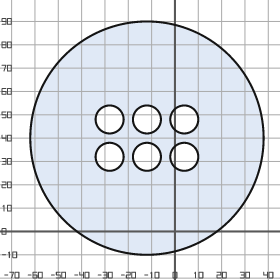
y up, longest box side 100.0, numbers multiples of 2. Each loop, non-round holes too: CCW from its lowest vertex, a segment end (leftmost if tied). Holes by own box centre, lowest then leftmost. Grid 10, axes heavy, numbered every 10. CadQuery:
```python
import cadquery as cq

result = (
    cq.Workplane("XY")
    .moveTo(-12.0, 40.0)
    .circle(50.0)
    .moveTo(-28.0, 32.0)
    .circle(6.0)
    .moveTo(-12.0, 32.0)
    .circle(6.0)
    .moveTo(4.0, 32.0)
    .circle(6.0)
    .moveTo(-28.0, 48.0)
    .circle(6.0)
    .moveTo(-12.0, 48.0)
    .circle(6.0)
    .moveTo(4.0, 48.0)
    .circle(6.0)
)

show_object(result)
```